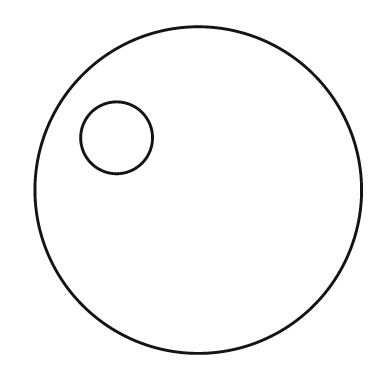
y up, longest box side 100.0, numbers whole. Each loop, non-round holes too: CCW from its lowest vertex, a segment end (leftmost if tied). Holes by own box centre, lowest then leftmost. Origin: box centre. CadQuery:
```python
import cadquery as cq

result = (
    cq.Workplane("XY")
    .moveTo(0.0, 0.0)
    .circle(50.0)
    .moveTo(-25.0, 16.0)
    .circle(11.0)
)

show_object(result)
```